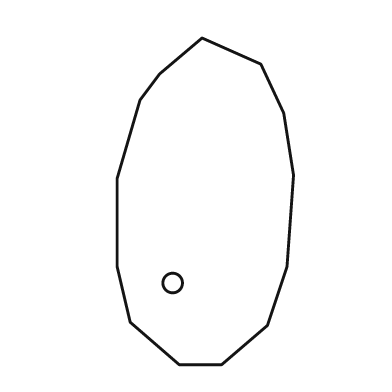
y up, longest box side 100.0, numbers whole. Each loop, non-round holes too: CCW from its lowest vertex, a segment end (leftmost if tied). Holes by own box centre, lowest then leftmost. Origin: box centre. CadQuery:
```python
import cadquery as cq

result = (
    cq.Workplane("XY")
    .moveTo(-8.0, -50.0)
    .lineTo(5.0, -50.0)
    .lineTo(19.0, -38.0)
    .lineTo(25.0, -20.0)
    .lineTo(27.0, 8.0)
    .lineTo(24.0, 27.0)
    .lineTo(17.0, 42.0)
    .lineTo(-1.0, 50.0)
    .lineTo(-14.0, 39.0)
    .lineTo(-20.0, 31.0)
    .lineTo(-27.0, 7.0)
    .lineTo(-27.0, -20.0)
    .lineTo(-23.0, -37.0)
    .close()
    .moveTo(-10.0, -25.0)
    .circle(3.0)
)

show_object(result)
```